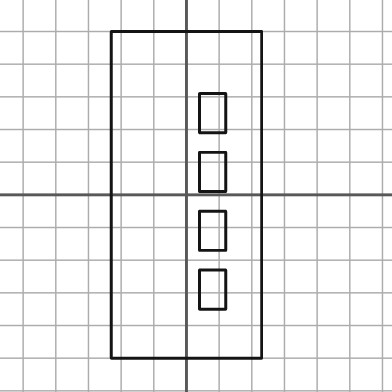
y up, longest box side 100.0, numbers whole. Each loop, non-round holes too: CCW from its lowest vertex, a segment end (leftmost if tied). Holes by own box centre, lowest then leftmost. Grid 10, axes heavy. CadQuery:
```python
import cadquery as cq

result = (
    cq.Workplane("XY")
    .moveTo(-23.0, -50.0)
    .lineTo(23.0, -50.0)
    .lineTo(23.0, 50.0)
    .lineTo(-23.0, 50.0)
    .close()
    .moveTo(4.0, -35.0)
    .lineTo(12.0, -35.0)
    .lineTo(12.0, -23.0)
    .lineTo(4.0, -23.0)
    .close()
    .moveTo(4.0, -17.0)
    .lineTo(12.0, -17.0)
    .lineTo(12.0, -5.0)
    .lineTo(4.0, -5.0)
    .close()
    .moveTo(4.0, 1.0)
    .lineTo(12.0, 1.0)
    .lineTo(12.0, 13.0)
    .lineTo(4.0, 13.0)
    .close()
    .moveTo(4.0, 19.0)
    .lineTo(12.0, 19.0)
    .lineTo(12.0, 31.0)
    .lineTo(4.0, 31.0)
    .close()
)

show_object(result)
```